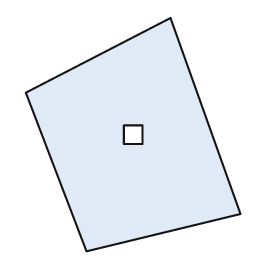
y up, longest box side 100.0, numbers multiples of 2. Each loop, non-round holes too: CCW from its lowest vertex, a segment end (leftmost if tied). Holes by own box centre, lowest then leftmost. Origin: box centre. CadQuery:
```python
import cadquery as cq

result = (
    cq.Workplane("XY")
    .moveTo(-20.0, -50.0)
    .lineTo(46.0, -34.0)
    .lineTo(16.0, 50.0)
    .lineTo(-46.0, 18.0)
    .close()
    .moveTo(-4.0, -4.0)
    .lineTo(4.0, -4.0)
    .lineTo(4.0, 4.0)
    .lineTo(-4.0, 4.0)
    .close()
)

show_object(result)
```